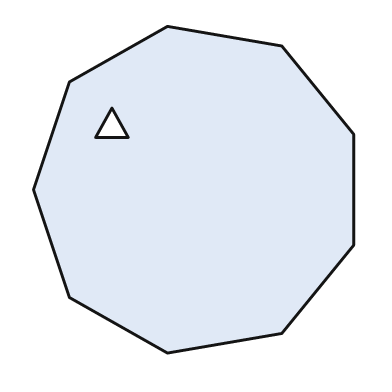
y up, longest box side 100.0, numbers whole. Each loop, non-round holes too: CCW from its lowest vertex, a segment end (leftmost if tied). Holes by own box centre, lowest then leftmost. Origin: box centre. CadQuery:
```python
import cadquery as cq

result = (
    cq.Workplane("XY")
    .moveTo(-8.0, -50.0)
    .lineTo(27.0, -44.0)
    .lineTo(49.0, -17.0)
    .lineTo(49.0, 17.0)
    .lineTo(27.0, 44.0)
    .lineTo(-8.0, 50.0)
    .lineTo(-38.0, 33.0)
    .lineTo(-49.0, 0.0)
    .lineTo(-38.0, -33.0)
    .close()
    .moveTo(-30.0, 16.0)
    .lineTo(-20.0, 16.0)
    .lineTo(-25.0, 25.0)
    .close()
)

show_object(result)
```